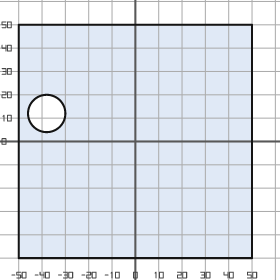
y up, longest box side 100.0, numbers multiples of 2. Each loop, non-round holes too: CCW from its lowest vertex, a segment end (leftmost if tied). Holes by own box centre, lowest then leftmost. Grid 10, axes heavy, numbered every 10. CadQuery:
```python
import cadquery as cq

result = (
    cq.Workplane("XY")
    .moveTo(-50.0, -50.0)
    .lineTo(50.0, -50.0)
    .lineTo(50.0, 50.0)
    .lineTo(-50.0, 50.0)
    .close()
    .moveTo(-38.0, 12.0)
    .circle(8.0)
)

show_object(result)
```